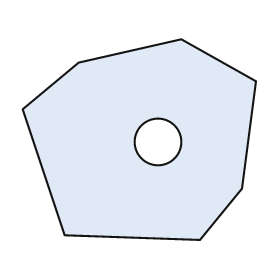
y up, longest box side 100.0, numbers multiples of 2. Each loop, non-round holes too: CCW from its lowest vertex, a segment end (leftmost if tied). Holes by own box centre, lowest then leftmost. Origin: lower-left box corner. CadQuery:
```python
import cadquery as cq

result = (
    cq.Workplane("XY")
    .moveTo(76.0, 0.0)
    .lineTo(94.0, 22.0)
    .lineTo(100.0, 68.0)
    .lineTo(68.0, 86.0)
    .lineTo(24.0, 76.0)
    .lineTo(0.0, 56.0)
    .lineTo(18.0, 2.0)
    .close()
    .moveTo(58.0, 42.0)
    .circle(10.0)
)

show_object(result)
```